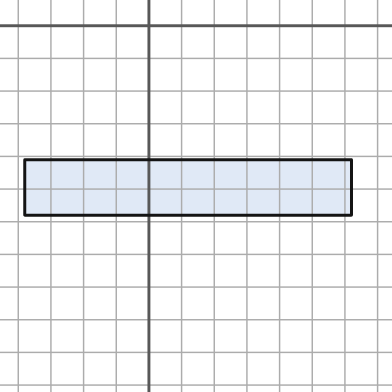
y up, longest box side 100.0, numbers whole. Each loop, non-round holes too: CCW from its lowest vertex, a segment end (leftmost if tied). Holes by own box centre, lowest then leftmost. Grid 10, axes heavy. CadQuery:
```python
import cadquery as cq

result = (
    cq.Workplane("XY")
    .moveTo(-38.0, -58.0)
    .lineTo(62.0, -58.0)
    .lineTo(62.0, -41.0)
    .lineTo(-38.0, -41.0)
    .close()
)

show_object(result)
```